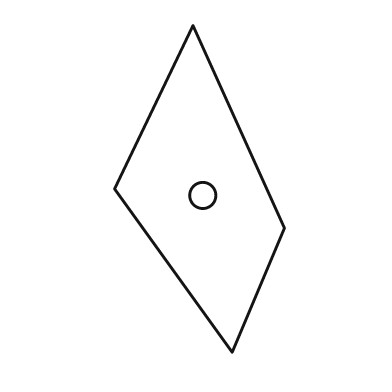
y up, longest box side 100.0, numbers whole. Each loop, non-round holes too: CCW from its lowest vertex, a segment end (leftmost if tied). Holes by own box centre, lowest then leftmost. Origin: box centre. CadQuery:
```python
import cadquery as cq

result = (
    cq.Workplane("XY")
    .moveTo(10.0, -50.0)
    .lineTo(26.0, -12.0)
    .lineTo(-2.0, 50.0)
    .lineTo(-26.0, 0.0)
    .close()
    .moveTo(1.0, -2.0)
    .circle(4.0)
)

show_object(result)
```